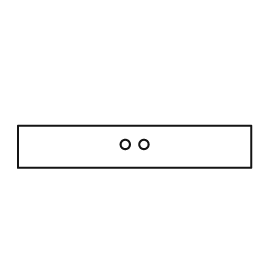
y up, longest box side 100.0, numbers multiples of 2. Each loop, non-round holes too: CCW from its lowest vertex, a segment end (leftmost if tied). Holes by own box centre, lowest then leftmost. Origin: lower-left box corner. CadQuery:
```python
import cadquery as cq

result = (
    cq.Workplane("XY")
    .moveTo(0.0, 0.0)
    .lineTo(100.0, 0.0)
    .lineTo(100.0, 18.0)
    .lineTo(0.0, 18.0)
    .close()
    .moveTo(46.0, 10.0)
    .circle(2.0)
    .moveTo(54.0, 10.0)
    .circle(2.0)
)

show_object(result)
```